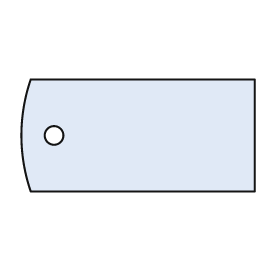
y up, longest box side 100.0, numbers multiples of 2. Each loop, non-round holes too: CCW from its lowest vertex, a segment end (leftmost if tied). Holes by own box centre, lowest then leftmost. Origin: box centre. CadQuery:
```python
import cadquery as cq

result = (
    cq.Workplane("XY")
    .moveTo(-46.0, -24.0)
    .lineTo(50.0, -24.0)
    .lineTo(50.0, 24.0)
    .lineTo(-46.0, 24.0)
    .threePointArc((-50.0, 0.0), (-46.0, -24.0))
    .close()
    .moveTo(-36.0, 0.0)
    .circle(4.0)
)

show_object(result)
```